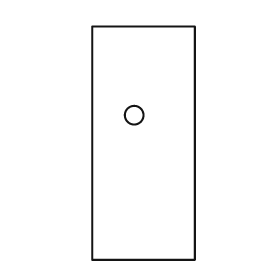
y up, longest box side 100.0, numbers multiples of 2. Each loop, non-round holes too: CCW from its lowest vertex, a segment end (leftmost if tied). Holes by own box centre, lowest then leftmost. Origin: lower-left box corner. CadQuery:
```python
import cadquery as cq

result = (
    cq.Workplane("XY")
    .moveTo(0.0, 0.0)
    .lineTo(44.0, 0.0)
    .lineTo(44.0, 100.0)
    .lineTo(0.0, 100.0)
    .close()
    .moveTo(18.0, 62.0)
    .circle(4.0)
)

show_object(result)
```